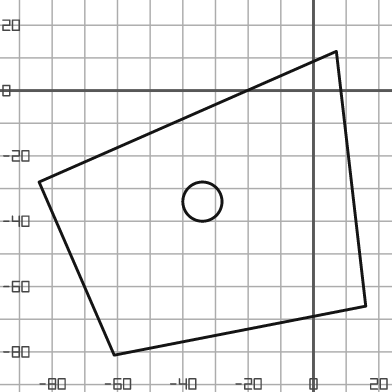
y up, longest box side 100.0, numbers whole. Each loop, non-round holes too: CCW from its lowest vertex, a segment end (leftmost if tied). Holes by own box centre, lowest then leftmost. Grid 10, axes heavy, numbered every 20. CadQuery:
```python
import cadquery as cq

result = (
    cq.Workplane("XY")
    .moveTo(-61.0, -81.0)
    .lineTo(16.0, -66.0)
    .lineTo(7.0, 12.0)
    .lineTo(-84.0, -28.0)
    .close()
    .moveTo(-34.0, -34.0)
    .circle(6.0)
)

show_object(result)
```